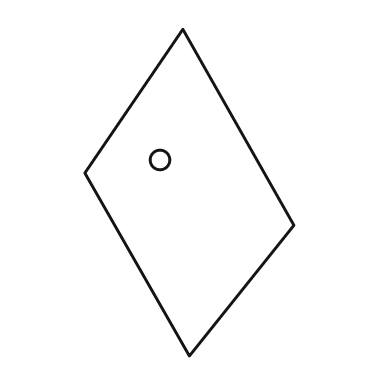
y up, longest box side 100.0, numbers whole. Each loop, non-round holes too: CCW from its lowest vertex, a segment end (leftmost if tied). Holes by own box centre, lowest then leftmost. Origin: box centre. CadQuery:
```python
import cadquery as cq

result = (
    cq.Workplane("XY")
    .moveTo(0.0, -50.0)
    .lineTo(32.0, -10.0)
    .lineTo(-2.0, 50.0)
    .lineTo(-32.0, 6.0)
    .close()
    .moveTo(-9.0, 10.0)
    .circle(3.0)
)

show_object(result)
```